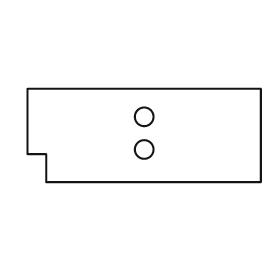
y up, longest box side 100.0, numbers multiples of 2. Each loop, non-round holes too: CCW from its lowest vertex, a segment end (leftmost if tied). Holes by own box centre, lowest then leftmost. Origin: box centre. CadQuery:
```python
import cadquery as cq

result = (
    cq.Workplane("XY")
    .moveTo(-42.0, -20.0)
    .lineTo(50.0, -20.0)
    .lineTo(50.0, 20.0)
    .lineTo(-50.0, 20.0)
    .lineTo(-50.0, -8.0)
    .lineTo(-42.0, -8.0)
    .close()
    .moveTo(0.0, -6.0)
    .circle(4.0)
    .moveTo(0.0, 8.0)
    .circle(4.0)
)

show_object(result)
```